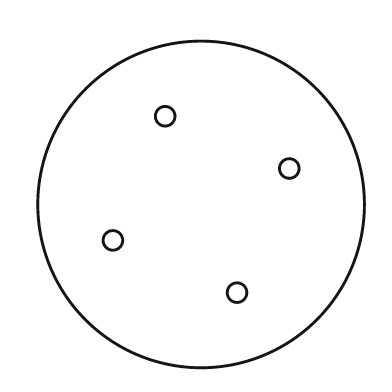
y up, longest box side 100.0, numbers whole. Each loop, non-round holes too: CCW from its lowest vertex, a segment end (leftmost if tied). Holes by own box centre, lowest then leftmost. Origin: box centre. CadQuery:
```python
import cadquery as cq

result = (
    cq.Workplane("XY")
    .moveTo(0.0, 0.0)
    .circle(50.0)
    .moveTo(11.0, -27.0)
    .circle(3.0)
    .moveTo(-27.0, -11.0)
    .circle(3.0)
    .moveTo(27.0, 11.0)
    .circle(3.0)
    .moveTo(-11.0, 27.0)
    .circle(3.0)
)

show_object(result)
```